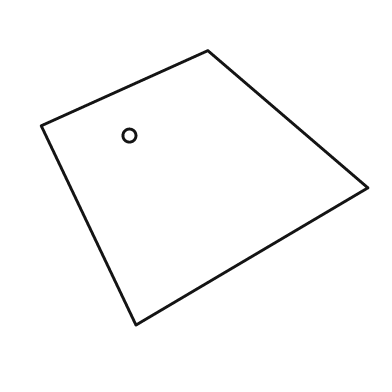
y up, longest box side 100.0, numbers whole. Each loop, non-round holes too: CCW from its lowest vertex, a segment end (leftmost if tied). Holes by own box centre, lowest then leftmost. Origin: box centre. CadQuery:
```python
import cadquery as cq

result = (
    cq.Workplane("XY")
    .moveTo(-21.0, -42.0)
    .lineTo(50.0, 0.0)
    .lineTo(1.0, 42.0)
    .lineTo(-50.0, 19.0)
    .close()
    .moveTo(-23.0, 16.0)
    .circle(2.0)
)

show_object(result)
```